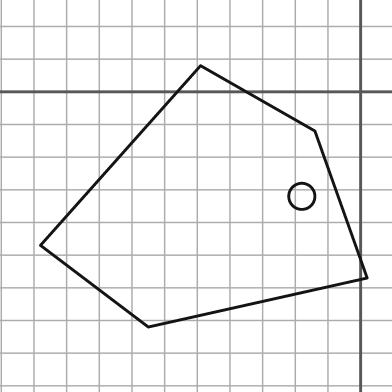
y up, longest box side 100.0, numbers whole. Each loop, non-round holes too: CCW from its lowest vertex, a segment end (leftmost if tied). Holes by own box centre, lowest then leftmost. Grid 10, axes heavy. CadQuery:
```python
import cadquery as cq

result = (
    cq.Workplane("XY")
    .moveTo(-65.0, -72.0)
    .lineTo(2.0, -57.0)
    .lineTo(-14.0, -12.0)
    .lineTo(-49.0, 8.0)
    .lineTo(-98.0, -47.0)
    .close()
    .moveTo(-18.0, -32.0)
    .circle(4.0)
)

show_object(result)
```